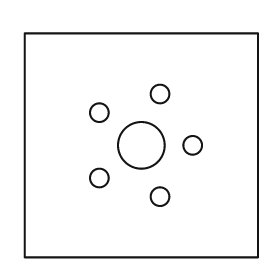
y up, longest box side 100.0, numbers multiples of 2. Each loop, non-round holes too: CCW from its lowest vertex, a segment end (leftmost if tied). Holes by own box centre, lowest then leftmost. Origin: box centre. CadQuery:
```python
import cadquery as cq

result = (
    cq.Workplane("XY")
    .moveTo(-50.0, -48.0)
    .lineTo(50.0, -48.0)
    .lineTo(50.0, 48.0)
    .lineTo(-50.0, 48.0)
    .close()
    .moveTo(8.0, -22.0)
    .circle(4.0)
    .moveTo(-18.0, -14.0)
    .circle(4.0)
    .moveTo(0.0, 0.0)
    .circle(10.0)
    .moveTo(22.0, 0.0)
    .circle(4.0)
    .moveTo(-18.0, 14.0)
    .circle(4.0)
    .moveTo(8.0, 22.0)
    .circle(4.0)
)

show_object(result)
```